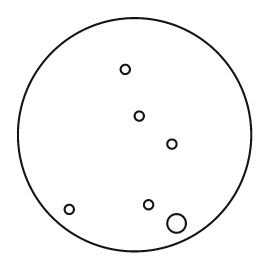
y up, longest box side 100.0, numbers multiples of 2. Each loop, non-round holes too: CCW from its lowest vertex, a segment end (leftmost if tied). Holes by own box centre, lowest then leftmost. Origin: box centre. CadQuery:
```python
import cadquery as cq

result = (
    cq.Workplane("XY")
    .moveTo(0.0, 0.0)
    .circle(50.0)
    .moveTo(18.0, -38.0)
    .circle(4.0)
    .moveTo(-28.0, -32.0)
    .circle(2.0)
    .moveTo(6.0, -30.0)
    .circle(2.0)
    .moveTo(16.0, -4.0)
    .circle(2.0)
    .moveTo(2.0, 8.0)
    .circle(2.0)
    .moveTo(-4.0, 28.0)
    .circle(2.0)
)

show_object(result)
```